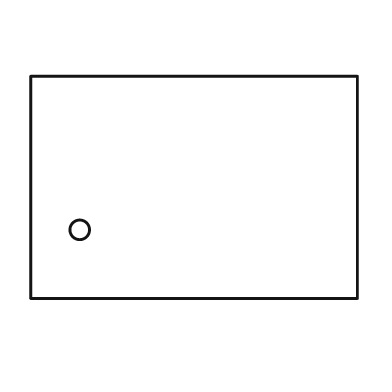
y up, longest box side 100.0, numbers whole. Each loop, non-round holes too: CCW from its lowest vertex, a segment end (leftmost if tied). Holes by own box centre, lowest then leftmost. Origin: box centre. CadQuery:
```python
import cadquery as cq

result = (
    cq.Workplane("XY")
    .moveTo(-50.0, -34.0)
    .lineTo(50.0, -34.0)
    .lineTo(50.0, 34.0)
    .lineTo(-50.0, 34.0)
    .close()
    .moveTo(-35.0, -13.0)
    .circle(3.0)
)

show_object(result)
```